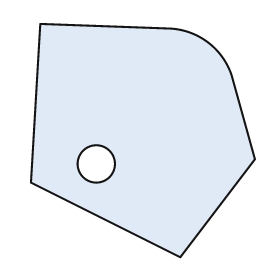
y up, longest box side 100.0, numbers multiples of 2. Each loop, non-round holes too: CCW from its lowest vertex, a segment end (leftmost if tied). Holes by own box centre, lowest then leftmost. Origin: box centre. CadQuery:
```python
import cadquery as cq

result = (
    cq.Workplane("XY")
    .moveTo(16.0, -50.0)
    .lineTo(48.0, -8.0)
    .lineTo(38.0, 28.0)
    .threePointArc((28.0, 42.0), (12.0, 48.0))
    .lineTo(-44.0, 50.0)
    .lineTo(-48.0, -18.0)
    .close()
    .moveTo(-20.0, -10.0)
    .circle(8.0)
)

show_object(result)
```